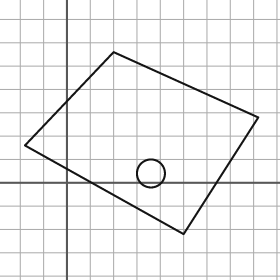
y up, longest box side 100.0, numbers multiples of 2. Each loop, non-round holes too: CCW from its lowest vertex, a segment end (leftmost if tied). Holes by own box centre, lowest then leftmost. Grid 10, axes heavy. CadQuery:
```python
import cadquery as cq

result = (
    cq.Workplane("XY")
    .moveTo(50.0, -22.0)
    .lineTo(82.0, 28.0)
    .lineTo(20.0, 56.0)
    .lineTo(-18.0, 16.0)
    .close()
    .moveTo(36.0, 4.0)
    .circle(6.0)
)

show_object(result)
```